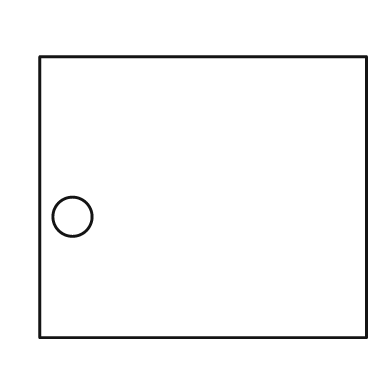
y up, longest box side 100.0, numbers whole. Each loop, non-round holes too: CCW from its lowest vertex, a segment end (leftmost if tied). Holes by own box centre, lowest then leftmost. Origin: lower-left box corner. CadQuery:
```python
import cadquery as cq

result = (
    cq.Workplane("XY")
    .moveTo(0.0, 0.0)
    .lineTo(100.0, 0.0)
    .lineTo(100.0, 86.0)
    .lineTo(0.0, 86.0)
    .close()
    .moveTo(10.0, 37.0)
    .circle(6.0)
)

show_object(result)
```